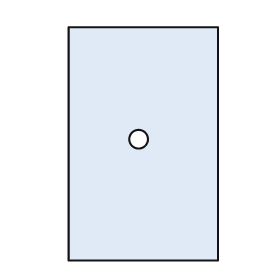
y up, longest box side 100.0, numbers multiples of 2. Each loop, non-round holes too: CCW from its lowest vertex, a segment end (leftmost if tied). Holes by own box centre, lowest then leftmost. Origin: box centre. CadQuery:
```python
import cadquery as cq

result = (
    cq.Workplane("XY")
    .moveTo(-32.0, -50.0)
    .lineTo(32.0, -50.0)
    .lineTo(32.0, 50.0)
    .lineTo(-32.0, 50.0)
    .close()
    .moveTo(-2.0, 2.0)
    .circle(4.0)
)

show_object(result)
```